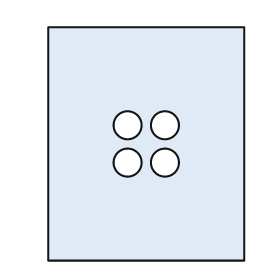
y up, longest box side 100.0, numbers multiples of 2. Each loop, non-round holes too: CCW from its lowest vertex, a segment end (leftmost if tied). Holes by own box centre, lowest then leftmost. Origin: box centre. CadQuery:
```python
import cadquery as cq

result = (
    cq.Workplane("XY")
    .moveTo(-42.0, -50.0)
    .lineTo(42.0, -50.0)
    .lineTo(42.0, 50.0)
    .lineTo(-42.0, 50.0)
    .close()
    .moveTo(-8.0, -8.0)
    .circle(6.0)
    .moveTo(8.0, -8.0)
    .circle(6.0)
    .moveTo(-8.0, 8.0)
    .circle(6.0)
    .moveTo(8.0, 8.0)
    .circle(6.0)
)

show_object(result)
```